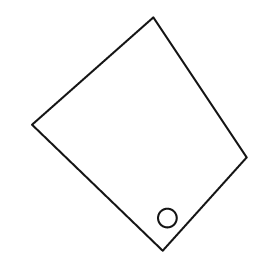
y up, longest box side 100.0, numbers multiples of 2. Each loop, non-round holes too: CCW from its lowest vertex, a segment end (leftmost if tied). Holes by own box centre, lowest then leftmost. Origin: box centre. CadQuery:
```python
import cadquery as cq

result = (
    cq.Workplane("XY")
    .moveTo(10.0, -50.0)
    .lineTo(46.0, -10.0)
    .lineTo(6.0, 50.0)
    .lineTo(-46.0, 4.0)
    .close()
    .moveTo(12.0, -36.0)
    .circle(4.0)
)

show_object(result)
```